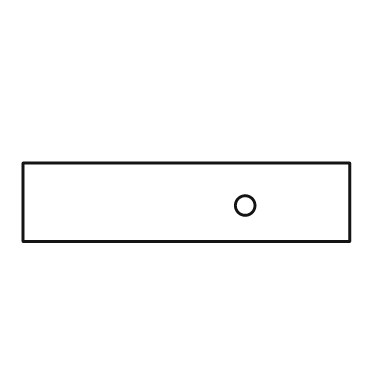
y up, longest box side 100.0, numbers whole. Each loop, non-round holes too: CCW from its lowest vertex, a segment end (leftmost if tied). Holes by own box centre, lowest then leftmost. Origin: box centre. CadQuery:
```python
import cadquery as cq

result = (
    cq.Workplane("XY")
    .moveTo(-50.0, -12.0)
    .lineTo(50.0, -12.0)
    .lineTo(50.0, 12.0)
    .lineTo(-50.0, 12.0)
    .close()
    .moveTo(18.0, -1.0)
    .circle(3.0)
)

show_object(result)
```